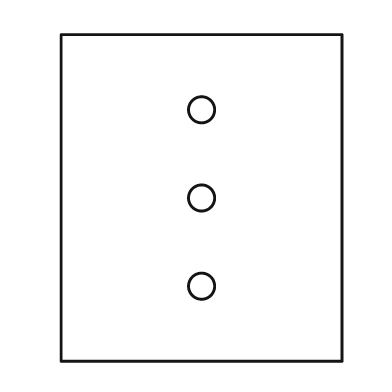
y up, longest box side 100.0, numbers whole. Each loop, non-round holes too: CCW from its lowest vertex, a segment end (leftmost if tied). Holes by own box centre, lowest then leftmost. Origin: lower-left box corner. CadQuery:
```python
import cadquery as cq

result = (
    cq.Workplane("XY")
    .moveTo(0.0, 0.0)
    .lineTo(86.0, 0.0)
    .lineTo(86.0, 100.0)
    .lineTo(0.0, 100.0)
    .close()
    .moveTo(43.0, 23.0)
    .circle(4.0)
    .moveTo(43.0, 50.0)
    .circle(4.0)
    .moveTo(43.0, 77.0)
    .circle(4.0)
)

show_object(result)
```